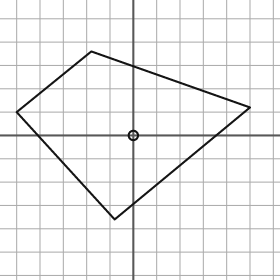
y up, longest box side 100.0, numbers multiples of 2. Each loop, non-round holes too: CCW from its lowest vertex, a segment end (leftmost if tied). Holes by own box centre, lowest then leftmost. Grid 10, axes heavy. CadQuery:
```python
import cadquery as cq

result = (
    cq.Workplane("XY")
    .moveTo(-8.0, -36.0)
    .lineTo(50.0, 12.0)
    .lineTo(-18.0, 36.0)
    .lineTo(-50.0, 10.0)
    .close()
    .moveTo(0.0, 0.0)
    .circle(2.0)
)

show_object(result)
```